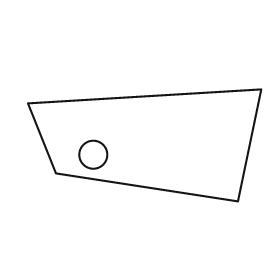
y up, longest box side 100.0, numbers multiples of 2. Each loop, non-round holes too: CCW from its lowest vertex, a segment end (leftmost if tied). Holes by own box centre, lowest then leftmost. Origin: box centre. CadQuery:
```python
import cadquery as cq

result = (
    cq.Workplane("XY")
    .moveTo(40.0, -24.0)
    .lineTo(50.0, 24.0)
    .lineTo(-50.0, 18.0)
    .lineTo(-38.0, -12.0)
    .close()
    .moveTo(-22.0, -4.0)
    .circle(6.0)
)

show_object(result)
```